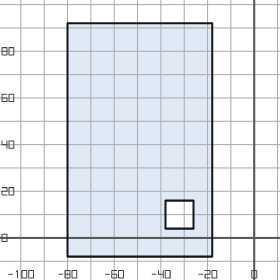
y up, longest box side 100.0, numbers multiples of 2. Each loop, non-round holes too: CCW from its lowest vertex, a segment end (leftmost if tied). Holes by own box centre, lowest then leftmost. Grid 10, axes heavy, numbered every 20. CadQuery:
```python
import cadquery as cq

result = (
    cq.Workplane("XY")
    .moveTo(-80.0, -8.0)
    .lineTo(-18.0, -8.0)
    .lineTo(-18.0, 92.0)
    .lineTo(-80.0, 92.0)
    .close()
    .moveTo(-38.0, 4.0)
    .lineTo(-26.0, 4.0)
    .lineTo(-26.0, 16.0)
    .lineTo(-38.0, 16.0)
    .close()
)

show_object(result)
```